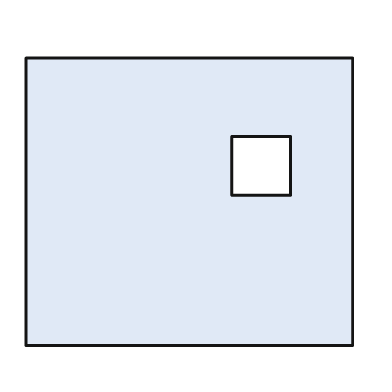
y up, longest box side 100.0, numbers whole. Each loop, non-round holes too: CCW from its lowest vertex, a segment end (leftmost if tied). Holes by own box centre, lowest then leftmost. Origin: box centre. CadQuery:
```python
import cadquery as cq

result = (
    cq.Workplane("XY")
    .moveTo(-50.0, -44.0)
    .lineTo(50.0, -44.0)
    .lineTo(50.0, 44.0)
    .lineTo(-50.0, 44.0)
    .close()
    .moveTo(13.0, 2.0)
    .lineTo(31.0, 2.0)
    .lineTo(31.0, 20.0)
    .lineTo(13.0, 20.0)
    .close()
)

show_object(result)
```